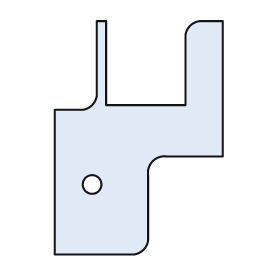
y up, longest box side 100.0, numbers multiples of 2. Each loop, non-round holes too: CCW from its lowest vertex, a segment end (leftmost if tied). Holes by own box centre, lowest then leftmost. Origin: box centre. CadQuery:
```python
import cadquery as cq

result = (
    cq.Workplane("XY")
    .moveTo(-36.0, -50.0)
    .lineTo(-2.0, -50.0)
    .threePointArc((2.0, -48.0), (4.0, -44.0))
    .lineTo(4.0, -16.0)
    .threePointArc((6.0, -10.0), (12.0, -8.0))
    .lineTo(36.0, -8.0)
    .lineTo(36.0, 50.0)
    .lineTo(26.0, 50.0)
    .threePointArc((22.0, 48.0), (20.0, 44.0))
    .lineTo(20.0, 14.0)
    .lineTo(-14.0, 14.0)
    .lineTo(-14.0, 50.0)
    .lineTo(-18.0, 50.0)
    .lineTo(-18.0, 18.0)
    .threePointArc((-20.0, 14.0), (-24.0, 12.0))
    .lineTo(-36.0, 12.0)
    .close()
    .moveTo(-20.0, -20.0)
    .circle(4.0)
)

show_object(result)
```